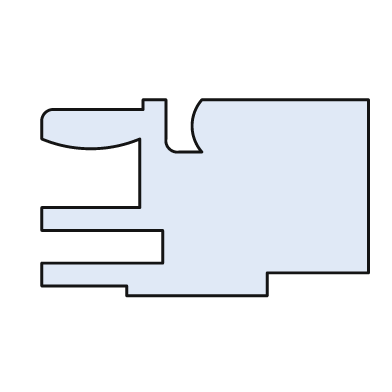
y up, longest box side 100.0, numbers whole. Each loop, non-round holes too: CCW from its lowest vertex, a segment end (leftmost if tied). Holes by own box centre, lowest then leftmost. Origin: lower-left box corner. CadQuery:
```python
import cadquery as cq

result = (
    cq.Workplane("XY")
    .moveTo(26.0, 0.0)
    .lineTo(69.0, 0.0)
    .lineTo(69.0, 7.0)
    .lineTo(100.0, 7.0)
    .lineTo(100.0, 60.0)
    .lineTo(49.0, 60.0)
    .threePointArc((46.0, 52.0), (49.0, 44.0))
    .lineTo(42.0, 44.0)
    .threePointArc((39.0, 45.0), (38.0, 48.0))
    .lineTo(38.0, 60.0)
    .lineTo(31.0, 60.0)
    .lineTo(31.0, 57.0)
    .lineTo(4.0, 57.0)
    .threePointArc((1.0, 56.0), (0.0, 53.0))
    .lineTo(0.0, 48.0)
    .threePointArc((15.0, 45.0), (30.0, 48.0))
    .lineTo(30.0, 27.0)
    .lineTo(0.0, 27.0)
    .lineTo(0.0, 20.0)
    .lineTo(37.0, 20.0)
    .lineTo(37.0, 10.0)
    .lineTo(0.0, 10.0)
    .lineTo(0.0, 3.0)
    .lineTo(26.0, 3.0)
    .close()
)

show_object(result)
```